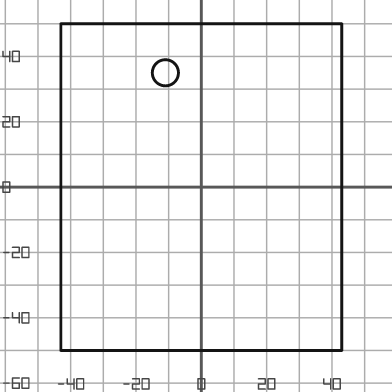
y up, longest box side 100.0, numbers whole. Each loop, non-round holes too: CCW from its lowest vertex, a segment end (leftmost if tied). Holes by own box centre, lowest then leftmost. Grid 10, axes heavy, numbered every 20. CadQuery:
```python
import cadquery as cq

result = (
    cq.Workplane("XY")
    .moveTo(-43.0, -50.0)
    .lineTo(43.0, -50.0)
    .lineTo(43.0, 50.0)
    .lineTo(-43.0, 50.0)
    .close()
    .moveTo(-11.0, 35.0)
    .circle(4.0)
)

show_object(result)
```